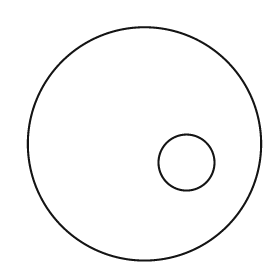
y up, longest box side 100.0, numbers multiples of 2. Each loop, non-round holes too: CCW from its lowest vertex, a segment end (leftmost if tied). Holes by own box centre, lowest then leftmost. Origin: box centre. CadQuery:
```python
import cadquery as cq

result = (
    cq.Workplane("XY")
    .moveTo(0.0, 0.0)
    .circle(50.0)
    .moveTo(18.0, -8.0)
    .circle(12.0)
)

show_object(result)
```